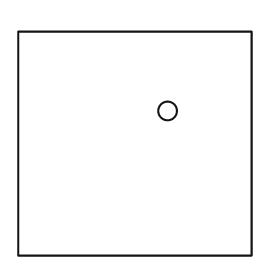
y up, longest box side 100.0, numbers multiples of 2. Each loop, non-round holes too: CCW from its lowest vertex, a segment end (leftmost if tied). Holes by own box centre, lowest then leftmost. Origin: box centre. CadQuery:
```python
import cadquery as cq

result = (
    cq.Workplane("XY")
    .moveTo(-50.0, -48.0)
    .lineTo(50.0, -48.0)
    .lineTo(50.0, 48.0)
    .lineTo(-50.0, 48.0)
    .close()
    .moveTo(14.0, 14.0)
    .circle(4.0)
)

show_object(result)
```